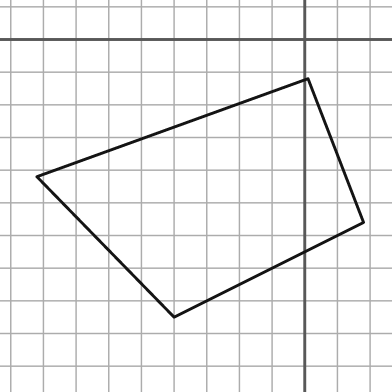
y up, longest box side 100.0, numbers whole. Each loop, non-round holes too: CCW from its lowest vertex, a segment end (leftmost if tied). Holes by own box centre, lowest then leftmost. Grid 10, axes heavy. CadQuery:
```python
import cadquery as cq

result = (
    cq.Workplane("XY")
    .moveTo(-40.0, -85.0)
    .lineTo(18.0, -56.0)
    .lineTo(1.0, -12.0)
    .lineTo(-82.0, -42.0)
    .close()
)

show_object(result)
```